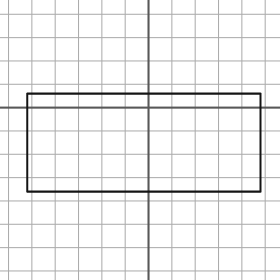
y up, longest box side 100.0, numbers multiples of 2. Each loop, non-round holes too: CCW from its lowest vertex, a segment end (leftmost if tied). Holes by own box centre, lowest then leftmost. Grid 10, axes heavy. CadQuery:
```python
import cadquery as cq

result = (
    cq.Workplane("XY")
    .moveTo(-52.0, -36.0)
    .lineTo(48.0, -36.0)
    .lineTo(48.0, 6.0)
    .lineTo(-52.0, 6.0)
    .close()
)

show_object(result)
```